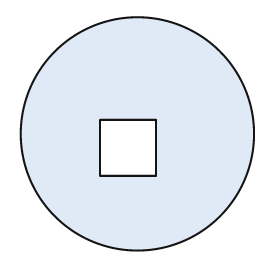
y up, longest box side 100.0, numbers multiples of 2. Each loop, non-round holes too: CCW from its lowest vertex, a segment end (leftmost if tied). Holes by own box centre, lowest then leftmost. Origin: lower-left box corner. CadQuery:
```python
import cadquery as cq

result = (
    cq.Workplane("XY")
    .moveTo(50.0, 50.0)
    .circle(50.0)
    .moveTo(34.0, 32.0)
    .lineTo(58.0, 32.0)
    .lineTo(58.0, 56.0)
    .lineTo(34.0, 56.0)
    .close()
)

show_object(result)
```